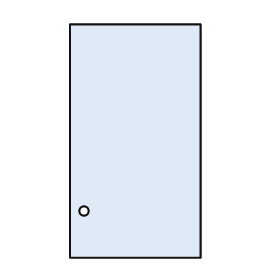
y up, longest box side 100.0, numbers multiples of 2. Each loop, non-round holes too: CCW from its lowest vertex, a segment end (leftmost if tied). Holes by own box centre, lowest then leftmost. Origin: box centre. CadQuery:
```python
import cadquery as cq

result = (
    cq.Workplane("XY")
    .moveTo(-28.0, -50.0)
    .lineTo(28.0, -50.0)
    .lineTo(28.0, 50.0)
    .lineTo(-28.0, 50.0)
    .close()
    .moveTo(-22.0, -30.0)
    .circle(2.0)
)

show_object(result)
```